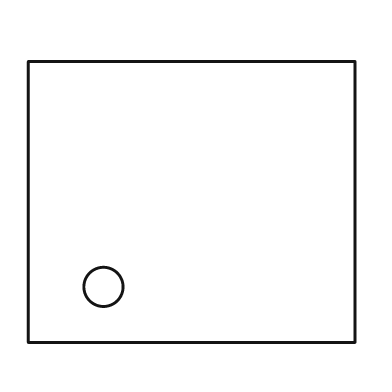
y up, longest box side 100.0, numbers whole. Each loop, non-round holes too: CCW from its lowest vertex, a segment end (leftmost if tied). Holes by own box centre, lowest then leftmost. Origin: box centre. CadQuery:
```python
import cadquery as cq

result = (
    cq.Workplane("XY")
    .moveTo(-50.0, -43.0)
    .lineTo(50.0, -43.0)
    .lineTo(50.0, 43.0)
    .lineTo(-50.0, 43.0)
    .close()
    .moveTo(-27.0, -26.0)
    .circle(6.0)
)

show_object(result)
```